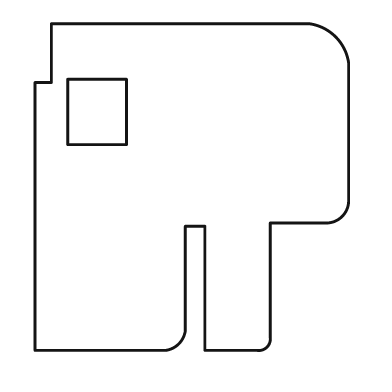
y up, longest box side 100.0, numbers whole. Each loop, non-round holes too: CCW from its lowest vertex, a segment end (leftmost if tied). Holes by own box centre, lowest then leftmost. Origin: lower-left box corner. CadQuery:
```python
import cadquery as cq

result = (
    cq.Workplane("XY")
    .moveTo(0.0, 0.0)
    .lineTo(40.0, 0.0)
    .threePointArc((44.0, 2.0), (46.0, 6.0))
    .lineTo(46.0, 38.0)
    .lineTo(52.0, 38.0)
    .lineTo(52.0, 0.0)
    .lineTo(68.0, 0.0)
    .threePointArc((71.0, 1.0), (72.0, 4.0))
    .lineTo(72.0, 39.0)
    .lineTo(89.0, 39.0)
    .threePointArc((94.0, 41.0), (96.0, 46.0))
    .lineTo(96.0, 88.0)
    .threePointArc((92.0, 96.0), (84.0, 100.0))
    .lineTo(5.0, 100.0)
    .lineTo(5.0, 82.0)
    .lineTo(0.0, 82.0)
    .close()
    .moveTo(10.0, 63.0)
    .lineTo(28.0, 63.0)
    .lineTo(28.0, 83.0)
    .lineTo(10.0, 83.0)
    .close()
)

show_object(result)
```